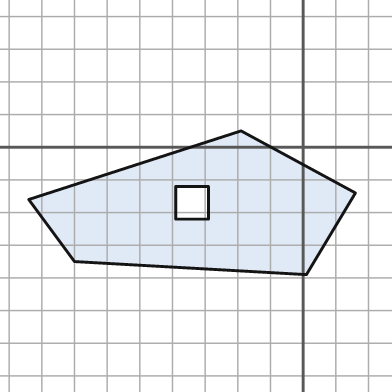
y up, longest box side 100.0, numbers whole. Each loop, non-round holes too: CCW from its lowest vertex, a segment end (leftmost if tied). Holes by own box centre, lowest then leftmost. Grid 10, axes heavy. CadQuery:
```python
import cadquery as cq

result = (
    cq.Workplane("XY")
    .moveTo(1.0, -39.0)
    .lineTo(16.0, -14.0)
    .lineTo(-19.0, 5.0)
    .lineTo(-84.0, -16.0)
    .lineTo(-70.0, -35.0)
    .close()
    .moveTo(-39.0, -22.0)
    .lineTo(-29.0, -22.0)
    .lineTo(-29.0, -12.0)
    .lineTo(-39.0, -12.0)
    .close()
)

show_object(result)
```